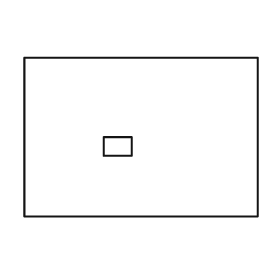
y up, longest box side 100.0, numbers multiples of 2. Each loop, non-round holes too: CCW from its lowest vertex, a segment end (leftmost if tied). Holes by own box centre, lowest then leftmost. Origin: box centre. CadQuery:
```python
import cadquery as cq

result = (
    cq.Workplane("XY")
    .moveTo(-50.0, -34.0)
    .lineTo(50.0, -34.0)
    .lineTo(50.0, 34.0)
    .lineTo(-50.0, 34.0)
    .close()
    .moveTo(-16.0, -8.0)
    .lineTo(-4.0, -8.0)
    .lineTo(-4.0, 0.0)
    .lineTo(-16.0, 0.0)
    .close()
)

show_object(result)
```